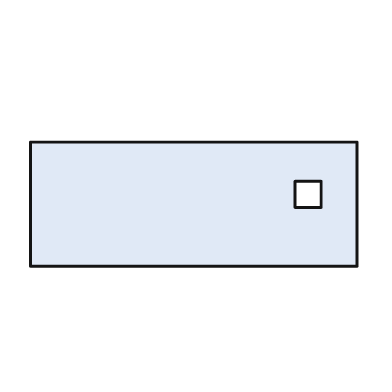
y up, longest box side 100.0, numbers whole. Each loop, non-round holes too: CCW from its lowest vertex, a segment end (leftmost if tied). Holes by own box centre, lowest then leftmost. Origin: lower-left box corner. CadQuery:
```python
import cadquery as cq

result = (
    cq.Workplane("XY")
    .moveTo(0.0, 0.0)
    .lineTo(100.0, 0.0)
    .lineTo(100.0, 38.0)
    .lineTo(0.0, 38.0)
    .close()
    .moveTo(81.0, 18.0)
    .lineTo(89.0, 18.0)
    .lineTo(89.0, 26.0)
    .lineTo(81.0, 26.0)
    .close()
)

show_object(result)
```